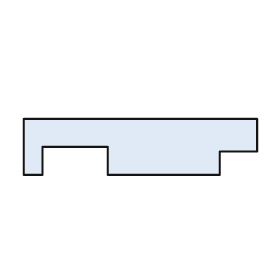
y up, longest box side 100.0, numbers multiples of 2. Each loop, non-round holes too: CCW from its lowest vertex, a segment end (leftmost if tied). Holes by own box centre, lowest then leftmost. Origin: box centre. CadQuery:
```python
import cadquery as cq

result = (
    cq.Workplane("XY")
    .moveTo(-50.0, -12.0)
    .lineTo(-42.0, -12.0)
    .lineTo(-42.0, 0.0)
    .lineTo(-14.0, 0.0)
    .lineTo(-14.0, -12.0)
    .lineTo(34.0, -12.0)
    .lineTo(34.0, -2.0)
    .lineTo(50.0, -2.0)
    .lineTo(50.0, 12.0)
    .lineTo(-50.0, 12.0)
    .close()
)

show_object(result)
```